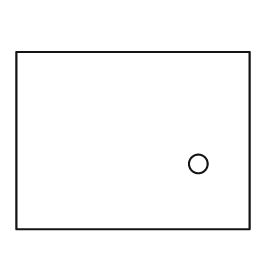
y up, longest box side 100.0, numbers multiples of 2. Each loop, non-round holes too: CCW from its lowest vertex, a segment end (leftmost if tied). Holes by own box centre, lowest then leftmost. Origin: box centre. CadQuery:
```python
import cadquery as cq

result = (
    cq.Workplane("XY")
    .moveTo(-50.0, -38.0)
    .lineTo(50.0, -38.0)
    .lineTo(50.0, 38.0)
    .lineTo(-50.0, 38.0)
    .close()
    .moveTo(28.0, -10.0)
    .circle(4.0)
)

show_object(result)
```